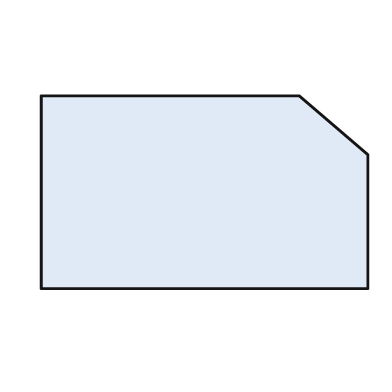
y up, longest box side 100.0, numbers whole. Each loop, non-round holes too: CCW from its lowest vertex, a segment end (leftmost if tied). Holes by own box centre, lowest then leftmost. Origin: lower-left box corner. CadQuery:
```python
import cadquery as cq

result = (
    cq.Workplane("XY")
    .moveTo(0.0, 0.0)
    .lineTo(100.0, 0.0)
    .lineTo(100.0, 41.0)
    .lineTo(79.0, 59.0)
    .lineTo(0.0, 59.0)
    .close()
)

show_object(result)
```